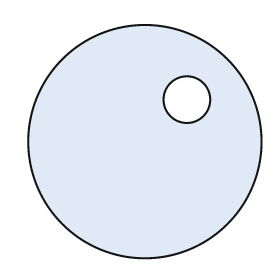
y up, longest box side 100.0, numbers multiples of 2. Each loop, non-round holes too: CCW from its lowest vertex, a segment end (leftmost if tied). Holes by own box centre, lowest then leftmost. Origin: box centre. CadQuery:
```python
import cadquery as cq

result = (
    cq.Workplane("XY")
    .moveTo(0.0, 0.0)
    .circle(50.0)
    .moveTo(18.0, 18.0)
    .circle(10.0)
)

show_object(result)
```